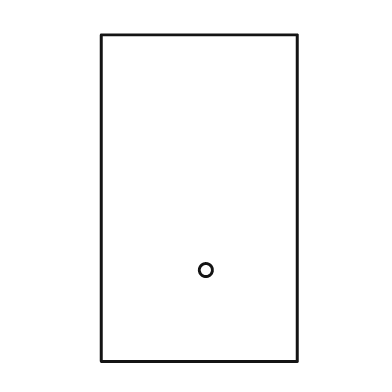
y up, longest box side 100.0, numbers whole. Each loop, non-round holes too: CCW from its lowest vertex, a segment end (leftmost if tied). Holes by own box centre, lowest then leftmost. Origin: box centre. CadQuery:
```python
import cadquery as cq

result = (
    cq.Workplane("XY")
    .moveTo(-30.0, -50.0)
    .lineTo(30.0, -50.0)
    .lineTo(30.0, 50.0)
    .lineTo(-30.0, 50.0)
    .close()
    .moveTo(2.0, -22.0)
    .circle(2.0)
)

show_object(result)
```